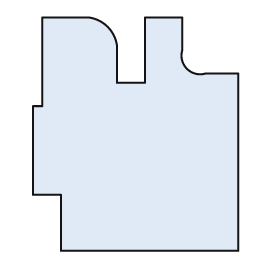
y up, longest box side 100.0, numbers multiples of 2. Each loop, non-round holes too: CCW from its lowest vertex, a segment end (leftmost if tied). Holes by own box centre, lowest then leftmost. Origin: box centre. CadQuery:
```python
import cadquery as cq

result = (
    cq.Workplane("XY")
    .moveTo(-32.0, -50.0)
    .lineTo(44.0, -50.0)
    .lineTo(44.0, 26.0)
    .lineTo(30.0, 26.0)
    .threePointArc((22.0, 28.0), (20.0, 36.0))
    .lineTo(20.0, 50.0)
    .lineTo(4.0, 50.0)
    .lineTo(4.0, 22.0)
    .lineTo(-8.0, 22.0)
    .lineTo(-8.0, 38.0)
    .threePointArc((-12.0, 46.0), (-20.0, 50.0))
    .lineTo(-40.0, 50.0)
    .lineTo(-40.0, 12.0)
    .lineTo(-44.0, 12.0)
    .lineTo(-44.0, -26.0)
    .lineTo(-32.0, -26.0)
    .close()
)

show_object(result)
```